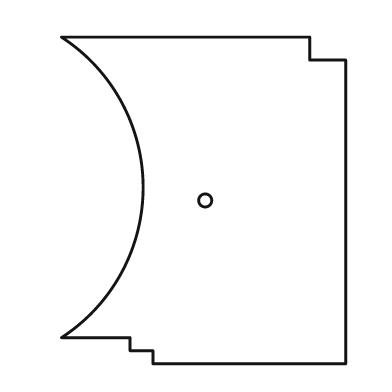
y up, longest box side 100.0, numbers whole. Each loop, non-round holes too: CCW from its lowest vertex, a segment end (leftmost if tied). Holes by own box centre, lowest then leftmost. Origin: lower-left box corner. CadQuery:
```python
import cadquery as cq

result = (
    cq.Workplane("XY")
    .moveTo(28.0, 0.0)
    .lineTo(87.0, 0.0)
    .lineTo(87.0, 93.0)
    .lineTo(76.0, 93.0)
    .lineTo(76.0, 100.0)
    .lineTo(0.0, 100.0)
    .threePointArc((25.0, 54.0), (0.0, 8.0))
    .lineTo(21.0, 8.0)
    .lineTo(21.0, 4.0)
    .lineTo(28.0, 4.0)
    .close()
    .moveTo(44.0, 50.0)
    .circle(2.0)
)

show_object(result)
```